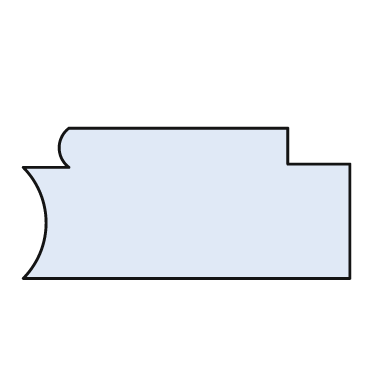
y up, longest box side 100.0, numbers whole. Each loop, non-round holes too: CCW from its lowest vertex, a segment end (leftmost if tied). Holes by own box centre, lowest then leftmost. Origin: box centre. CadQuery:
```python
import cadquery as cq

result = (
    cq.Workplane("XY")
    .moveTo(-50.0, -23.0)
    .lineTo(50.0, -23.0)
    .lineTo(50.0, 12.0)
    .lineTo(31.0, 12.0)
    .lineTo(31.0, 23.0)
    .lineTo(-36.0, 23.0)
    .threePointArc((-39.0, 17.0), (-36.0, 11.0))
    .lineTo(-50.0, 11.0)
    .threePointArc((-43.0, -6.0), (-50.0, -23.0))
    .close()
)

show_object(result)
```